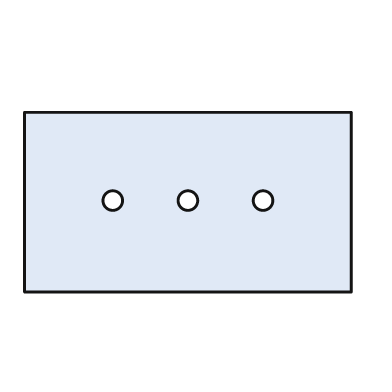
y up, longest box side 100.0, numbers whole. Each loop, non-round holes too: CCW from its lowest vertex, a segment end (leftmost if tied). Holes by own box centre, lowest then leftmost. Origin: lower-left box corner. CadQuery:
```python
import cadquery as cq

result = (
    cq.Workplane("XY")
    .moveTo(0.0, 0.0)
    .lineTo(100.0, 0.0)
    .lineTo(100.0, 55.0)
    .lineTo(0.0, 55.0)
    .close()
    .moveTo(27.0, 28.0)
    .circle(3.0)
    .moveTo(50.0, 28.0)
    .circle(3.0)
    .moveTo(73.0, 28.0)
    .circle(3.0)
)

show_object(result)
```